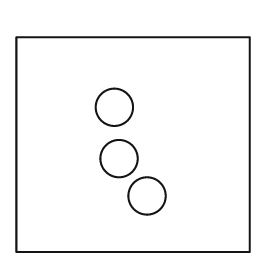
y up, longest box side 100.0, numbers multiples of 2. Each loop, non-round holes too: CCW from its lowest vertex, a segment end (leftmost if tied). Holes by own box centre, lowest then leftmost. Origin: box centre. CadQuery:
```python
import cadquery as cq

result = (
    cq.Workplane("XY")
    .moveTo(-50.0, -46.0)
    .lineTo(50.0, -46.0)
    .lineTo(50.0, 46.0)
    .lineTo(-50.0, 46.0)
    .close()
    .moveTo(6.0, -22.0)
    .circle(8.0)
    .moveTo(-6.0, -6.0)
    .circle(8.0)
    .moveTo(-8.0, 16.0)
    .circle(8.0)
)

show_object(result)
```